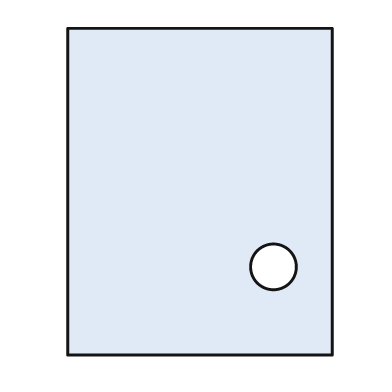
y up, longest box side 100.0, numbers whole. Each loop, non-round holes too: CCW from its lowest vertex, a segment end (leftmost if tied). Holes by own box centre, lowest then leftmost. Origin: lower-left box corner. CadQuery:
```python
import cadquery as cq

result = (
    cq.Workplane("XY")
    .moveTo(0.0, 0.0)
    .lineTo(81.0, 0.0)
    .lineTo(81.0, 100.0)
    .lineTo(0.0, 100.0)
    .close()
    .moveTo(63.0, 27.0)
    .circle(7.0)
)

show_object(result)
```